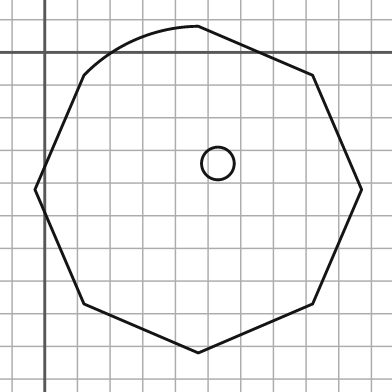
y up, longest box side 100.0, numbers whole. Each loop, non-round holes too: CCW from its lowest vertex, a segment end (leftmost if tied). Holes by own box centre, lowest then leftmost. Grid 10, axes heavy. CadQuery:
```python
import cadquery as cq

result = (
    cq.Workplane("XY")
    .moveTo(47.0, -92.0)
    .lineTo(82.0, -77.0)
    .lineTo(97.0, -42.0)
    .lineTo(82.0, -7.0)
    .lineTo(47.0, 8.0)
    .threePointArc((28.0, 4.0), (12.0, -7.0))
    .lineTo(-3.0, -42.0)
    .lineTo(12.0, -77.0)
    .close()
    .moveTo(53.0, -34.0)
    .circle(5.0)
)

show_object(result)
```